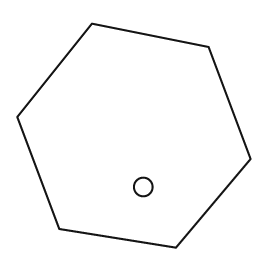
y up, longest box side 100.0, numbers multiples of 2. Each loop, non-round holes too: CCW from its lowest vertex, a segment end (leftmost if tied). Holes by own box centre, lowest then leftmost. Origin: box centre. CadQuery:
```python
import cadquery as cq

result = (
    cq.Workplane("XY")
    .moveTo(18.0, -48.0)
    .lineTo(50.0, -10.0)
    .lineTo(32.0, 38.0)
    .lineTo(-18.0, 48.0)
    .lineTo(-50.0, 8.0)
    .lineTo(-32.0, -40.0)
    .close()
    .moveTo(4.0, -22.0)
    .circle(4.0)
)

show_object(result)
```